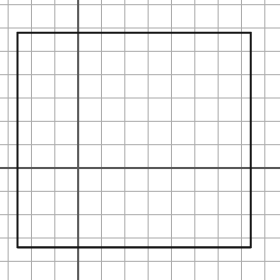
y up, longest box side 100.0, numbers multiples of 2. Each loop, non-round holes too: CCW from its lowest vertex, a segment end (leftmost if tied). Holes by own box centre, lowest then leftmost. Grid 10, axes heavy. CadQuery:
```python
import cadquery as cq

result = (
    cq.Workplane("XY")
    .moveTo(-26.0, -34.0)
    .lineTo(74.0, -34.0)
    .lineTo(74.0, 58.0)
    .lineTo(-26.0, 58.0)
    .close()
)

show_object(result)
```